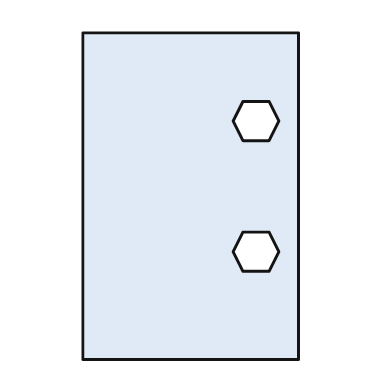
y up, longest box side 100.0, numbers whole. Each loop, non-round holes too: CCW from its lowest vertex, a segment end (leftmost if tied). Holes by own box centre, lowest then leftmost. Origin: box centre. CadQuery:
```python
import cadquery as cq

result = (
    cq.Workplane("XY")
    .moveTo(-33.0, -50.0)
    .lineTo(33.0, -50.0)
    .lineTo(33.0, 50.0)
    .lineTo(-33.0, 50.0)
    .close()
    .moveTo(16.0, -23.0)
    .lineTo(24.0, -23.0)
    .lineTo(27.0, -17.0)
    .lineTo(24.0, -11.0)
    .lineTo(16.0, -11.0)
    .lineTo(13.0, -17.0)
    .close()
    .moveTo(16.0, 17.0)
    .lineTo(24.0, 17.0)
    .lineTo(27.0, 23.0)
    .lineTo(24.0, 29.0)
    .lineTo(16.0, 29.0)
    .lineTo(13.0, 23.0)
    .close()
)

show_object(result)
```